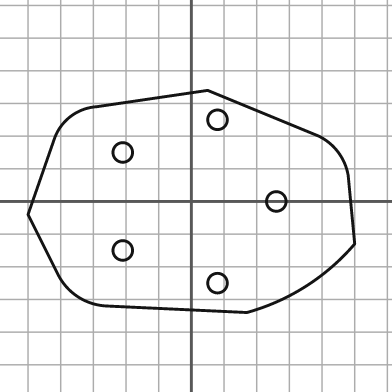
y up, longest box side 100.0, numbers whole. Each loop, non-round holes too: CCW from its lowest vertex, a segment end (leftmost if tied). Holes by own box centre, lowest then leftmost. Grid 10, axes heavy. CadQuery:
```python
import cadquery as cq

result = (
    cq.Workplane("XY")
    .moveTo(17.0, -34.0)
    .threePointArc((35.0, -26.0), (50.0, -13.0))
    .lineTo(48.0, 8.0)
    .threePointArc((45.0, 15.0), (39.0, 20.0))
    .lineTo(5.0, 34.0)
    .lineTo(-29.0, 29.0)
    .threePointArc((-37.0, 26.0), (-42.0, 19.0))
    .lineTo(-50.0, -4.0)
    .lineTo(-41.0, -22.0)
    .threePointArc((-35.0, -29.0), (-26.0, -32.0))
    .close()
    .moveTo(8.0, -25.0)
    .circle(3.0)
    .moveTo(-21.0, -15.0)
    .circle(3.0)
    .moveTo(26.0, 0.0)
    .circle(3.0)
    .moveTo(-21.0, 15.0)
    .circle(3.0)
    .moveTo(8.0, 25.0)
    .circle(3.0)
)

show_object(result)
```